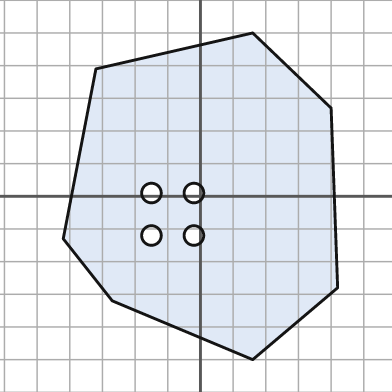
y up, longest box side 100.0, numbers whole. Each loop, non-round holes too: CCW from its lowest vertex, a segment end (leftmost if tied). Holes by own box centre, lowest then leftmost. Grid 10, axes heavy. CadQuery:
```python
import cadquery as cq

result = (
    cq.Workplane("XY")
    .moveTo(16.0, -50.0)
    .lineTo(42.0, -28.0)
    .lineTo(40.0, 27.0)
    .lineTo(16.0, 50.0)
    .lineTo(-32.0, 39.0)
    .lineTo(-42.0, -13.0)
    .lineTo(-27.0, -32.0)
    .close()
    .moveTo(-15.0, -12.0)
    .circle(3.0)
    .moveTo(-2.0, -12.0)
    .circle(3.0)
    .moveTo(-15.0, 1.0)
    .circle(3.0)
    .moveTo(-2.0, 1.0)
    .circle(3.0)
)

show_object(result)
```